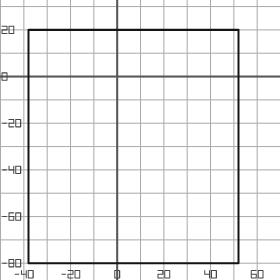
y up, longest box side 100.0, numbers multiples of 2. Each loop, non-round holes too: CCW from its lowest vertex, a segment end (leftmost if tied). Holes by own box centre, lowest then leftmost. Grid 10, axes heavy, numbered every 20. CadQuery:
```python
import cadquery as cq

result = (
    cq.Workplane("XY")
    .moveTo(-38.0, -80.0)
    .lineTo(52.0, -80.0)
    .lineTo(52.0, 20.0)
    .lineTo(-38.0, 20.0)
    .close()
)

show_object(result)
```